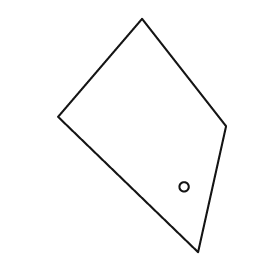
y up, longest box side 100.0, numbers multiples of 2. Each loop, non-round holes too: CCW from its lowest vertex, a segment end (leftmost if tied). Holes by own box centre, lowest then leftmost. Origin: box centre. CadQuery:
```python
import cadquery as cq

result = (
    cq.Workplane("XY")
    .moveTo(24.0, -50.0)
    .lineTo(36.0, 4.0)
    .lineTo(0.0, 50.0)
    .lineTo(-36.0, 8.0)
    .close()
    .moveTo(18.0, -22.0)
    .circle(2.0)
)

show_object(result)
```